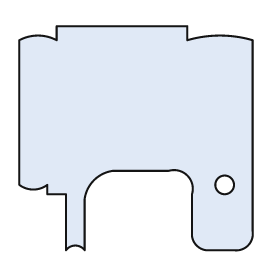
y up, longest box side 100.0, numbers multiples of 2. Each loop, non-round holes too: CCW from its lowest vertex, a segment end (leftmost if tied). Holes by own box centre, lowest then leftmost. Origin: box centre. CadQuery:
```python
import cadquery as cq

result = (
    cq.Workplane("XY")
    .moveTo(-30.0, -48.0)
    .threePointArc((-26.0, -46.0), (-22.0, -48.0))
    .lineTo(-22.0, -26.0)
    .threePointArc((-18.0, -18.0), (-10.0, -14.0))
    .lineTo(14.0, -14.0)
    .threePointArc((22.0, -16.0), (24.0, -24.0))
    .lineTo(24.0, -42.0)
    .threePointArc((26.0, -46.0), (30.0, -48.0))
    .lineTo(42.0, -48.0)
    .threePointArc((48.0, -46.0), (50.0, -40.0))
    .lineTo(50.0, 42.0)
    .threePointArc((36.0, 44.0), (22.0, 42.0))
    .lineTo(22.0, 48.0)
    .lineTo(-34.0, 48.0)
    .lineTo(-34.0, 42.0)
    .threePointArc((-42.0, 44.0), (-50.0, 42.0))
    .lineTo(-50.0, -20.0)
    .threePointArc((-44.0, -22.0), (-38.0, -20.0))
    .lineTo(-38.0, -24.0)
    .lineTo(-30.0, -24.0)
    .close()
    .moveTo(38.0, -20.0)
    .circle(4.0)
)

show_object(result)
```